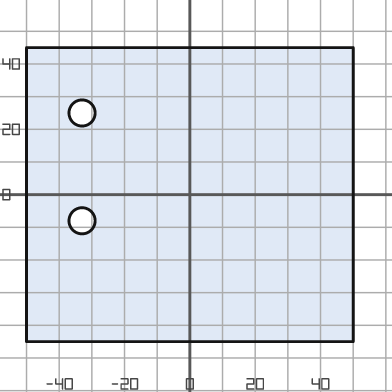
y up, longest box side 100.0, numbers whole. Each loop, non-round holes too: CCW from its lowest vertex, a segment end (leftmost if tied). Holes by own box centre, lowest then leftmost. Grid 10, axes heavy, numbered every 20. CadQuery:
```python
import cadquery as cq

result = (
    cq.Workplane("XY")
    .moveTo(-50.0, -45.0)
    .lineTo(50.0, -45.0)
    .lineTo(50.0, 45.0)
    .lineTo(-50.0, 45.0)
    .close()
    .moveTo(-33.0, -8.0)
    .circle(4.0)
    .moveTo(-33.0, 25.0)
    .circle(4.0)
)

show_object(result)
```